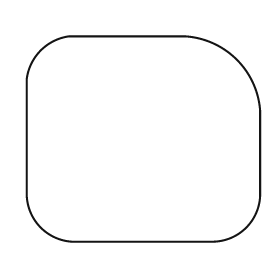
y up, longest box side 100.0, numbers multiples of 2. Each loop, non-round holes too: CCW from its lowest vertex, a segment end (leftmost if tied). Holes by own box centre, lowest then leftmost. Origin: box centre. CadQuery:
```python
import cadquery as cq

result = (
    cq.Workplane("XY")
    .moveTo(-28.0, -44.0)
    .lineTo(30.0, -44.0)
    .threePointArc((44.0, -38.0), (50.0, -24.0))
    .lineTo(50.0, 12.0)
    .threePointArc((40.0, 34.0), (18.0, 44.0))
    .lineTo(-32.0, 44.0)
    .threePointArc((-44.0, 38.0), (-50.0, 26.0))
    .lineTo(-50.0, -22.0)
    .threePointArc((-44.0, -38.0), (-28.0, -44.0))
    .close()
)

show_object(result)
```